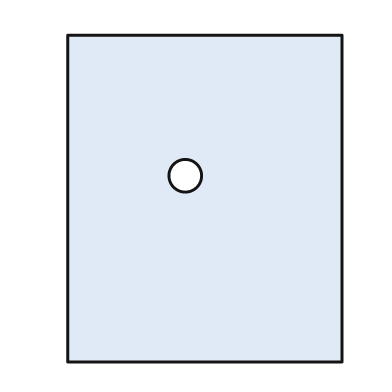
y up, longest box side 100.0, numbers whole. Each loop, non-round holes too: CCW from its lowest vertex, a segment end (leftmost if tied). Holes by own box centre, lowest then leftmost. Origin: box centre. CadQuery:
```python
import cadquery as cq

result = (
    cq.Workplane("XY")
    .moveTo(-42.0, -50.0)
    .lineTo(42.0, -50.0)
    .lineTo(42.0, 50.0)
    .lineTo(-42.0, 50.0)
    .close()
    .moveTo(-6.0, 7.0)
    .circle(5.0)
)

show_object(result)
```